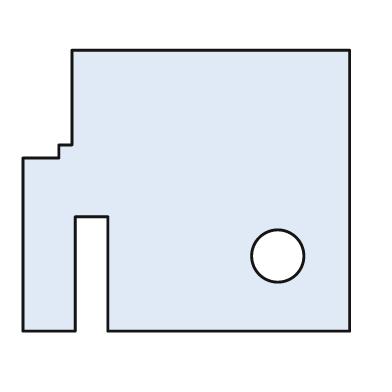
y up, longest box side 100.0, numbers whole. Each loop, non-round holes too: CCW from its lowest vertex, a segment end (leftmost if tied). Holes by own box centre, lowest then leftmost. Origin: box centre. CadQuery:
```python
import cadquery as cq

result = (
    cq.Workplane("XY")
    .moveTo(-50.0, -43.0)
    .lineTo(-34.0, -43.0)
    .lineTo(-34.0, -8.0)
    .lineTo(-24.0, -8.0)
    .lineTo(-24.0, -43.0)
    .lineTo(50.0, -43.0)
    .lineTo(50.0, 43.0)
    .lineTo(-35.0, 43.0)
    .lineTo(-35.0, 14.0)
    .lineTo(-39.0, 14.0)
    .lineTo(-39.0, 10.0)
    .lineTo(-50.0, 10.0)
    .close()
    .moveTo(28.0, -20.0)
    .circle(8.0)
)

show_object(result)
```